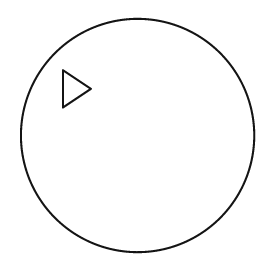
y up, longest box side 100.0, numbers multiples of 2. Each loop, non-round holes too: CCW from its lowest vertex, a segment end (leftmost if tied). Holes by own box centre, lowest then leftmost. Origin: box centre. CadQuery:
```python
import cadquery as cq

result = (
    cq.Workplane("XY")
    .moveTo(0.0, 0.0)
    .circle(50.0)
    .moveTo(-32.0, 12.0)
    .lineTo(-20.0, 20.0)
    .lineTo(-32.0, 28.0)
    .close()
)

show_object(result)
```